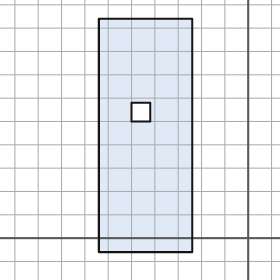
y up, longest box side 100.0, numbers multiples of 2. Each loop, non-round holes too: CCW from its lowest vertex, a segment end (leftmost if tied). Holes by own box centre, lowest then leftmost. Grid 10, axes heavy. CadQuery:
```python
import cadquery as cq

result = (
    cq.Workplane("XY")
    .moveTo(-64.0, -6.0)
    .lineTo(-24.0, -6.0)
    .lineTo(-24.0, 94.0)
    .lineTo(-64.0, 94.0)
    .close()
    .moveTo(-50.0, 50.0)
    .lineTo(-42.0, 50.0)
    .lineTo(-42.0, 58.0)
    .lineTo(-50.0, 58.0)
    .close()
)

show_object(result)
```